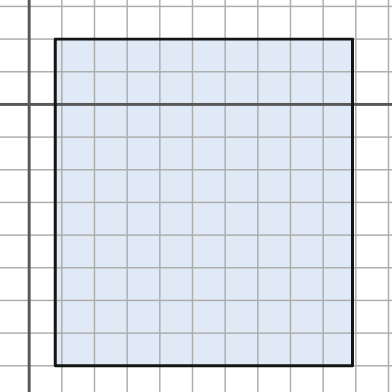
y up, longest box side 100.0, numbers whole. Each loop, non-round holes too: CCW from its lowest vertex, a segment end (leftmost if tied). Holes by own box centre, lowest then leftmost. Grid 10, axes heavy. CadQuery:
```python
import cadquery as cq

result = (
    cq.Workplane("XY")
    .moveTo(8.0, -80.0)
    .lineTo(99.0, -80.0)
    .lineTo(99.0, 20.0)
    .lineTo(8.0, 20.0)
    .close()
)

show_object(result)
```